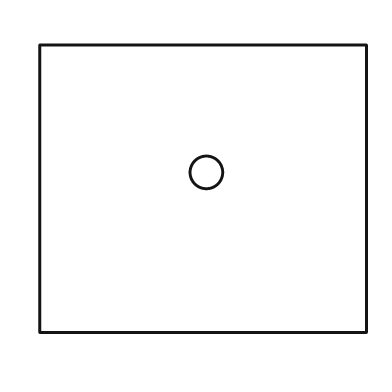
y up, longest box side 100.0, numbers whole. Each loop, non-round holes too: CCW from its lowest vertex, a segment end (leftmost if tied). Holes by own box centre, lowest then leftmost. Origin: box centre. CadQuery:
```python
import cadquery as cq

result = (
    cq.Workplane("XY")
    .moveTo(-50.0, -44.0)
    .lineTo(50.0, -44.0)
    .lineTo(50.0, 44.0)
    .lineTo(-50.0, 44.0)
    .close()
    .moveTo(1.0, 5.0)
    .circle(5.0)
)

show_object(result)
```